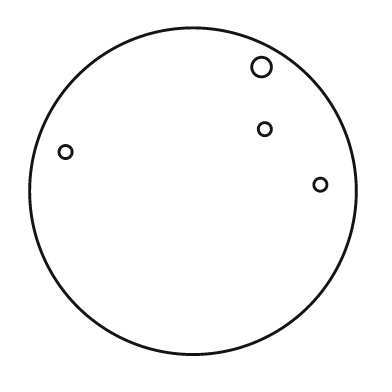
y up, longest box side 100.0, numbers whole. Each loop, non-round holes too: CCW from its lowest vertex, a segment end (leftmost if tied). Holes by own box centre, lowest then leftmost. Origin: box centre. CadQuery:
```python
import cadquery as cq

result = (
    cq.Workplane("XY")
    .moveTo(0.0, 0.0)
    .circle(50.0)
    .moveTo(39.0, 2.0)
    .circle(2.0)
    .moveTo(-39.0, 12.0)
    .circle(2.0)
    .moveTo(22.0, 19.0)
    .circle(2.0)
    .moveTo(21.0, 38.0)
    .circle(3.0)
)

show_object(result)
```